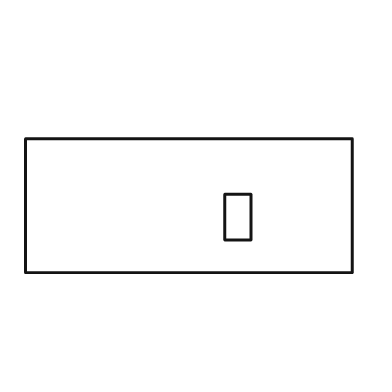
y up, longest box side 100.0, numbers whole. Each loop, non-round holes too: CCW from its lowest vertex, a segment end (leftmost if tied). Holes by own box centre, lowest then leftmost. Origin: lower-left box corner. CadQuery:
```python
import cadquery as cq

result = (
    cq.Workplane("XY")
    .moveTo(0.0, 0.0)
    .lineTo(100.0, 0.0)
    .lineTo(100.0, 41.0)
    .lineTo(0.0, 41.0)
    .close()
    .moveTo(61.0, 10.0)
    .lineTo(69.0, 10.0)
    .lineTo(69.0, 24.0)
    .lineTo(61.0, 24.0)
    .close()
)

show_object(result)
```